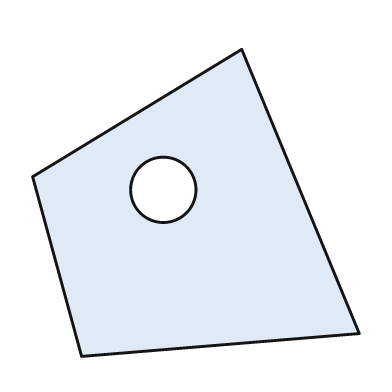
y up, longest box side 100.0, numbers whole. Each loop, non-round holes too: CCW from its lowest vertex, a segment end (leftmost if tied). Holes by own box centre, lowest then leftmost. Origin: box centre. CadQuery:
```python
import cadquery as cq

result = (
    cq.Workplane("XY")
    .moveTo(-35.0, -47.0)
    .lineTo(50.0, -40.0)
    .lineTo(14.0, 47.0)
    .lineTo(-50.0, 8.0)
    .close()
    .moveTo(-10.0, 4.0)
    .circle(10.0)
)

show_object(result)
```